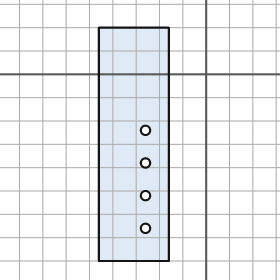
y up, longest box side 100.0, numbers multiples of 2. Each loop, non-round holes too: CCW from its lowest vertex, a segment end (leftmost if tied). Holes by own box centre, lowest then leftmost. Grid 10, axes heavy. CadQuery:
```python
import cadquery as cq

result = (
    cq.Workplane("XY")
    .moveTo(-46.0, -80.0)
    .lineTo(-16.0, -80.0)
    .lineTo(-16.0, 20.0)
    .lineTo(-46.0, 20.0)
    .close()
    .moveTo(-26.0, -66.0)
    .circle(2.0)
    .moveTo(-26.0, -52.0)
    .circle(2.0)
    .moveTo(-26.0, -38.0)
    .circle(2.0)
    .moveTo(-26.0, -24.0)
    .circle(2.0)
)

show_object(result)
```